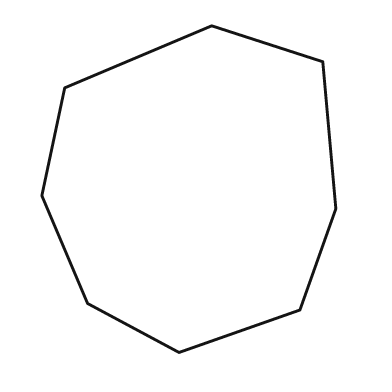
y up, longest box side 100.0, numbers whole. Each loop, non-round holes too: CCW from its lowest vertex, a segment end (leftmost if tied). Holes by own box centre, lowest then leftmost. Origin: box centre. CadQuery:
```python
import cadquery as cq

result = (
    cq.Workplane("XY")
    .moveTo(-3.0, -50.0)
    .lineTo(34.0, -37.0)
    .lineTo(45.0, -6.0)
    .lineTo(41.0, 39.0)
    .lineTo(7.0, 50.0)
    .lineTo(-38.0, 31.0)
    .lineTo(-45.0, -2.0)
    .lineTo(-31.0, -35.0)
    .close()
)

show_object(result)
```